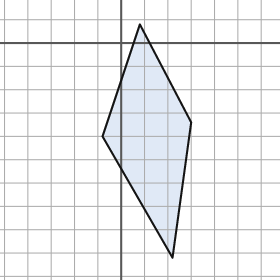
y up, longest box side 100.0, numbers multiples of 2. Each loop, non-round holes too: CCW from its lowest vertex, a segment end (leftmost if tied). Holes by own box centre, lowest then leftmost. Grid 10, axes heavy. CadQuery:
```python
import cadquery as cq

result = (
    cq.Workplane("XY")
    .moveTo(22.0, -92.0)
    .lineTo(30.0, -34.0)
    .lineTo(8.0, 8.0)
    .lineTo(-8.0, -40.0)
    .close()
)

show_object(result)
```